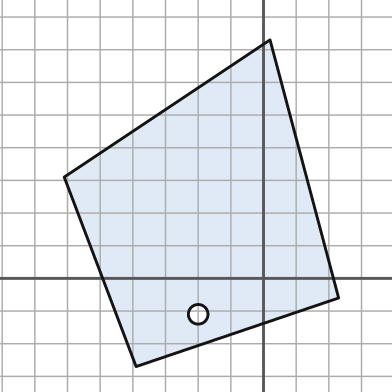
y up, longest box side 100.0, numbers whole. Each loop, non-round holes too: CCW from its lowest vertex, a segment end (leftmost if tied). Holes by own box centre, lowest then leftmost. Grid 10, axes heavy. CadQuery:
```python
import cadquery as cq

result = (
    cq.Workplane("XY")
    .moveTo(-39.0, -27.0)
    .lineTo(23.0, -6.0)
    .lineTo(2.0, 73.0)
    .lineTo(-61.0, 31.0)
    .close()
    .moveTo(-20.0, -11.0)
    .circle(3.0)
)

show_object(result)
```